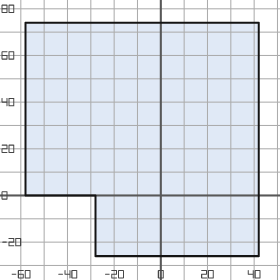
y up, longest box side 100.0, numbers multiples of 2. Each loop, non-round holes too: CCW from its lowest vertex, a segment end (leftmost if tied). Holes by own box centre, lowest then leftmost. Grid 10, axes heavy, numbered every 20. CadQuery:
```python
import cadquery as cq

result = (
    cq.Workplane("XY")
    .moveTo(-28.0, -26.0)
    .lineTo(42.0, -26.0)
    .lineTo(42.0, 74.0)
    .lineTo(-58.0, 74.0)
    .lineTo(-58.0, 0.0)
    .lineTo(-28.0, 0.0)
    .close()
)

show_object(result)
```